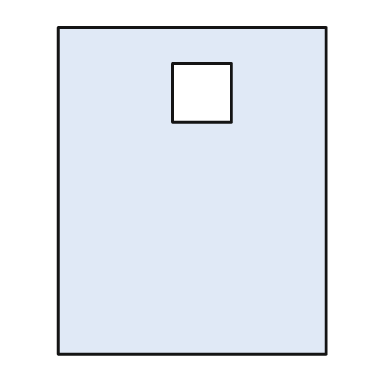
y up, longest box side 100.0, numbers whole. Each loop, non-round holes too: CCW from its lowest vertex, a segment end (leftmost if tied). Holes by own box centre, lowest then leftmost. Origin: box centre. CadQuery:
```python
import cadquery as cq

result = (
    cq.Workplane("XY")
    .moveTo(-41.0, -50.0)
    .lineTo(41.0, -50.0)
    .lineTo(41.0, 50.0)
    .lineTo(-41.0, 50.0)
    .close()
    .moveTo(-6.0, 21.0)
    .lineTo(12.0, 21.0)
    .lineTo(12.0, 39.0)
    .lineTo(-6.0, 39.0)
    .close()
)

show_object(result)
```